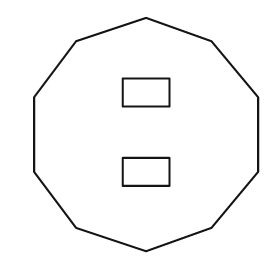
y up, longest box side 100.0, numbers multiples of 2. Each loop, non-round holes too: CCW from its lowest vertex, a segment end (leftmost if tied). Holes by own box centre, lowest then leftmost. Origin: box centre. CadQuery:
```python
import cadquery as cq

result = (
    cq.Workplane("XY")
    .moveTo(0.0, -50.0)
    .lineTo(28.0, -40.0)
    .lineTo(48.0, -16.0)
    .lineTo(48.0, 16.0)
    .lineTo(28.0, 40.0)
    .lineTo(0.0, 50.0)
    .lineTo(-30.0, 40.0)
    .lineTo(-48.0, 16.0)
    .lineTo(-48.0, -16.0)
    .lineTo(-30.0, -40.0)
    .close()
    .moveTo(-10.0, -22.0)
    .lineTo(10.0, -22.0)
    .lineTo(10.0, -10.0)
    .lineTo(-10.0, -10.0)
    .close()
    .moveTo(-10.0, 12.0)
    .lineTo(10.0, 12.0)
    .lineTo(10.0, 24.0)
    .lineTo(-10.0, 24.0)
    .close()
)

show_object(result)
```